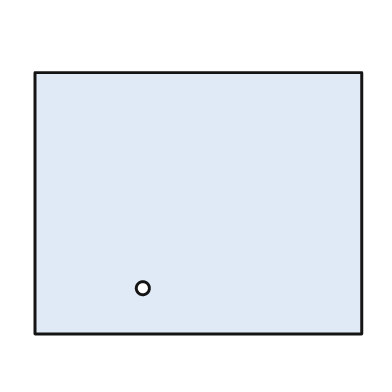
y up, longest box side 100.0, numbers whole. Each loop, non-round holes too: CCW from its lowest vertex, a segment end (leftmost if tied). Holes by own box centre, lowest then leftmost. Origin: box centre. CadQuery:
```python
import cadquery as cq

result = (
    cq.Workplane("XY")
    .moveTo(-50.0, -40.0)
    .lineTo(50.0, -40.0)
    .lineTo(50.0, 40.0)
    .lineTo(-50.0, 40.0)
    .close()
    .moveTo(-17.0, -26.0)
    .circle(2.0)
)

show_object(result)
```